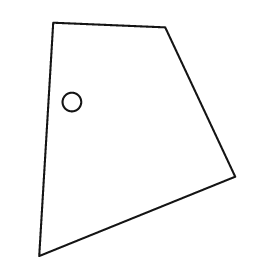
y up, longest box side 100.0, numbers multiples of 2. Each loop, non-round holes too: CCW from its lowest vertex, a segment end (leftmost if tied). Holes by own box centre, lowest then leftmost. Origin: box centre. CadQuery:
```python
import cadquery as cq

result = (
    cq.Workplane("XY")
    .moveTo(-42.0, -50.0)
    .lineTo(42.0, -16.0)
    .lineTo(12.0, 48.0)
    .lineTo(-36.0, 50.0)
    .close()
    .moveTo(-28.0, 16.0)
    .circle(4.0)
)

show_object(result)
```